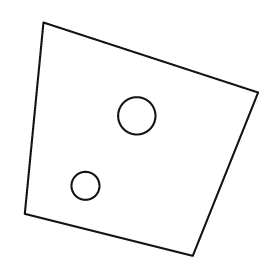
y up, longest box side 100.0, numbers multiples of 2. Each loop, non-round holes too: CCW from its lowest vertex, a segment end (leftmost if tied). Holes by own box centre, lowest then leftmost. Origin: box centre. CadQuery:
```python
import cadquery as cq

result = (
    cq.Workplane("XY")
    .moveTo(22.0, -50.0)
    .lineTo(50.0, 20.0)
    .lineTo(-42.0, 50.0)
    .lineTo(-50.0, -32.0)
    .close()
    .moveTo(-24.0, -20.0)
    .circle(6.0)
    .moveTo(-2.0, 10.0)
    .circle(8.0)
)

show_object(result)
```